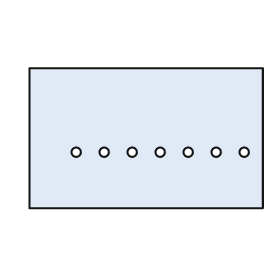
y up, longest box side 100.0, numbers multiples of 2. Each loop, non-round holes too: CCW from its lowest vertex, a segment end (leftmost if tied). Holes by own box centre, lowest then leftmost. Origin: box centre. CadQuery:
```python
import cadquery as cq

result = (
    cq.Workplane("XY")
    .moveTo(-50.0, -30.0)
    .lineTo(50.0, -30.0)
    .lineTo(50.0, 30.0)
    .lineTo(-50.0, 30.0)
    .close()
    .moveTo(-30.0, -6.0)
    .circle(2.0)
    .moveTo(-18.0, -6.0)
    .circle(2.0)
    .moveTo(-6.0, -6.0)
    .circle(2.0)
    .moveTo(6.0, -6.0)
    .circle(2.0)
    .moveTo(18.0, -6.0)
    .circle(2.0)
    .moveTo(30.0, -6.0)
    .circle(2.0)
    .moveTo(42.0, -6.0)
    .circle(2.0)
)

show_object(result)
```